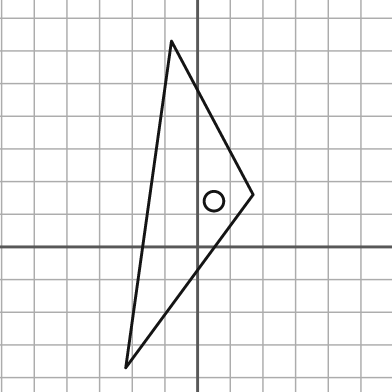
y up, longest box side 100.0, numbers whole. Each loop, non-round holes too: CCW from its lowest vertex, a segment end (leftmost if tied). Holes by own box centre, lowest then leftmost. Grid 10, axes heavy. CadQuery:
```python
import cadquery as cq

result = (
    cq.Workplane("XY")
    .moveTo(-22.0, -37.0)
    .lineTo(17.0, 16.0)
    .lineTo(-8.0, 63.0)
    .close()
    .moveTo(5.0, 14.0)
    .circle(3.0)
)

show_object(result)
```